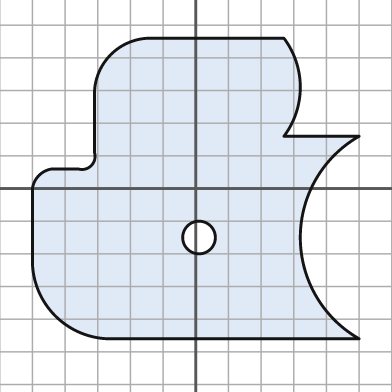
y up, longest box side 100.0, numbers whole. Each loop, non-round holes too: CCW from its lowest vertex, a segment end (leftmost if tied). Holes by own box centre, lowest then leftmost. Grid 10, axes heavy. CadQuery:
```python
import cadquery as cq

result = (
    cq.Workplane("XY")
    .moveTo(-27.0, -46.0)
    .lineTo(50.0, -46.0)
    .threePointArc((32.0, -15.0), (50.0, 16.0))
    .lineTo(27.0, 16.0)
    .threePointArc((32.0, 31.0), (27.0, 46.0))
    .lineTo(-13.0, 46.0)
    .threePointArc((-26.0, 41.0), (-31.0, 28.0))
    .lineTo(-31.0, 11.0)
    .threePointArc((-32.0, 7.0), (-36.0, 6.0))
    .lineTo(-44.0, 6.0)
    .threePointArc((-48.0, 4.0), (-50.0, 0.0))
    .lineTo(-50.0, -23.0)
    .threePointArc((-43.0, -39.0), (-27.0, -46.0))
    .close()
    .moveTo(1.0, -15.0)
    .circle(5.0)
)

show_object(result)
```